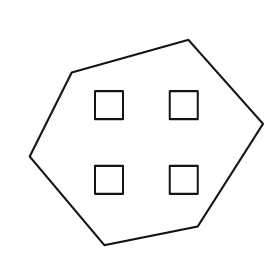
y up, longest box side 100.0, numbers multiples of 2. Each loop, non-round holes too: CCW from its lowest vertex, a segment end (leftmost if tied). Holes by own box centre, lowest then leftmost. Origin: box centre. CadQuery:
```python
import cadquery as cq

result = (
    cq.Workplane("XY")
    .moveTo(-18.0, -44.0)
    .lineTo(22.0, -36.0)
    .lineTo(50.0, 8.0)
    .lineTo(18.0, 44.0)
    .lineTo(-32.0, 30.0)
    .lineTo(-50.0, -6.0)
    .close()
    .moveTo(-22.0, -22.0)
    .lineTo(-10.0, -22.0)
    .lineTo(-10.0, -10.0)
    .lineTo(-22.0, -10.0)
    .close()
    .moveTo(10.0, -22.0)
    .lineTo(22.0, -22.0)
    .lineTo(22.0, -10.0)
    .lineTo(10.0, -10.0)
    .close()
    .moveTo(-22.0, 10.0)
    .lineTo(-10.0, 10.0)
    .lineTo(-10.0, 22.0)
    .lineTo(-22.0, 22.0)
    .close()
    .moveTo(10.0, 10.0)
    .lineTo(22.0, 10.0)
    .lineTo(22.0, 22.0)
    .lineTo(10.0, 22.0)
    .close()
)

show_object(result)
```